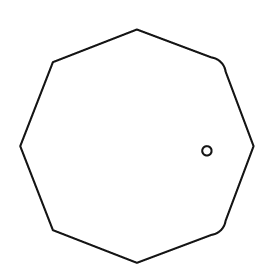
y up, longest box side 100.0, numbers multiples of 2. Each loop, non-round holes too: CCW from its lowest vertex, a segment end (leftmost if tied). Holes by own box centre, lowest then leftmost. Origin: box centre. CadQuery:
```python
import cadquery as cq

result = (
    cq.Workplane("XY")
    .moveTo(0.0, -50.0)
    .lineTo(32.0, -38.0)
    .threePointArc((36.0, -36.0), (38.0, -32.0))
    .lineTo(50.0, 0.0)
    .lineTo(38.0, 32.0)
    .threePointArc((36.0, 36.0), (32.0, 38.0))
    .lineTo(0.0, 50.0)
    .lineTo(-36.0, 36.0)
    .lineTo(-50.0, 0.0)
    .lineTo(-36.0, -36.0)
    .close()
    .moveTo(30.0, -2.0)
    .circle(2.0)
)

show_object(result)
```